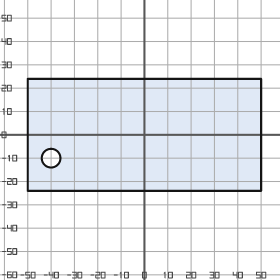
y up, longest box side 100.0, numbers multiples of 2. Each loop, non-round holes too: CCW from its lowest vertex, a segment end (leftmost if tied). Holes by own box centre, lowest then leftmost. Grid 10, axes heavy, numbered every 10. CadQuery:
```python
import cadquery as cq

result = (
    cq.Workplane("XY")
    .moveTo(-50.0, -24.0)
    .lineTo(50.0, -24.0)
    .lineTo(50.0, 24.0)
    .lineTo(-50.0, 24.0)
    .close()
    .moveTo(-40.0, -10.0)
    .circle(4.0)
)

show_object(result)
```